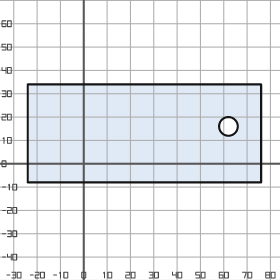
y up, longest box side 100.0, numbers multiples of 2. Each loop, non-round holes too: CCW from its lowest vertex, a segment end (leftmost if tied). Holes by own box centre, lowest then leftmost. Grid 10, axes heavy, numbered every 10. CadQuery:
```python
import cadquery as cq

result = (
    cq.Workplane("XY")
    .moveTo(-24.0, -8.0)
    .lineTo(76.0, -8.0)
    .lineTo(76.0, 34.0)
    .lineTo(-24.0, 34.0)
    .close()
    .moveTo(62.0, 16.0)
    .circle(4.0)
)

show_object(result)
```